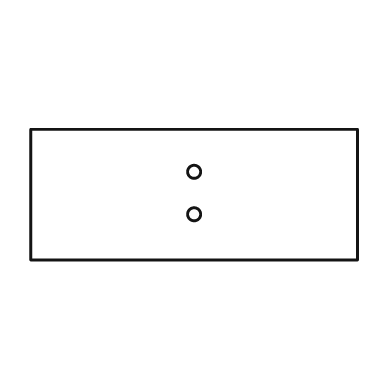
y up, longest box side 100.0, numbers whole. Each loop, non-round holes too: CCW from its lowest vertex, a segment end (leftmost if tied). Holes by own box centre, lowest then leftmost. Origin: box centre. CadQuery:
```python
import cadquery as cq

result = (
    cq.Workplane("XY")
    .moveTo(-50.0, -20.0)
    .lineTo(50.0, -20.0)
    .lineTo(50.0, 20.0)
    .lineTo(-50.0, 20.0)
    .close()
    .moveTo(0.0, -6.0)
    .circle(2.0)
    .moveTo(0.0, 7.0)
    .circle(2.0)
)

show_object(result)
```